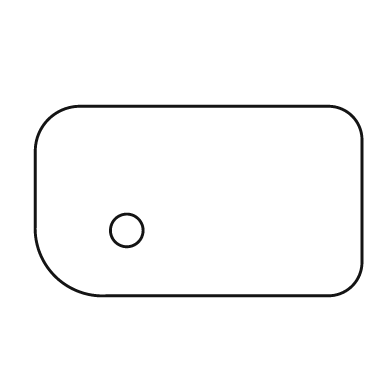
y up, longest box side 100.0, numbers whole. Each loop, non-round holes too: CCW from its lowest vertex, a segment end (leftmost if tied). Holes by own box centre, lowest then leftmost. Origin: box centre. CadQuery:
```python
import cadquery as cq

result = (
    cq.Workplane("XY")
    .moveTo(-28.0, -29.0)
    .lineTo(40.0, -29.0)
    .threePointArc((47.0, -26.0), (50.0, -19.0))
    .lineTo(50.0, 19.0)
    .threePointArc((47.0, 26.0), (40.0, 29.0))
    .lineTo(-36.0, 29.0)
    .threePointArc((-46.0, 25.0), (-50.0, 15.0))
    .lineTo(-50.0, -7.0)
    .threePointArc((-44.0, -23.0), (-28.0, -29.0))
    .close()
    .moveTo(-22.0, -9.0)
    .circle(5.0)
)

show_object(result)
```